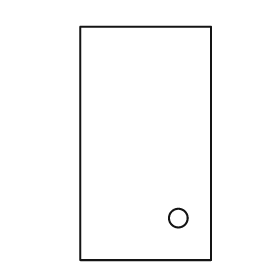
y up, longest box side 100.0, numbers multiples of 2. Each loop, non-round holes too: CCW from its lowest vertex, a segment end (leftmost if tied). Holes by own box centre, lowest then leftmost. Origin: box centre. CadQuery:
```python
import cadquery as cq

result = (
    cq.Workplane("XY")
    .moveTo(-28.0, -50.0)
    .lineTo(28.0, -50.0)
    .lineTo(28.0, 50.0)
    .lineTo(-28.0, 50.0)
    .close()
    .moveTo(14.0, -32.0)
    .circle(4.0)
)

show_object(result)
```